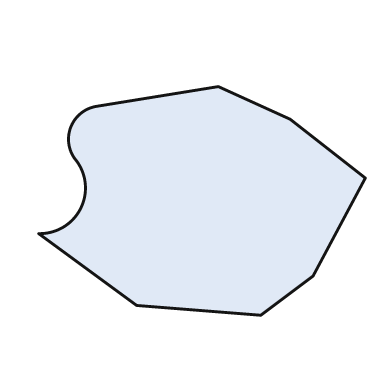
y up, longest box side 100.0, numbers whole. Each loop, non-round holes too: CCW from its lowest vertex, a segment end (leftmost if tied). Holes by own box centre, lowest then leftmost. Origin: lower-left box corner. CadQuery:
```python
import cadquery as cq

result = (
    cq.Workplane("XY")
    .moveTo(68.0, 0.0)
    .lineTo(84.0, 12.0)
    .lineTo(100.0, 42.0)
    .lineTo(77.0, 60.0)
    .lineTo(55.0, 70.0)
    .lineTo(18.0, 64.0)
    .threePointArc((10.0, 58.0), (11.0, 48.0))
    .threePointArc((13.0, 33.0), (0.0, 25.0))
    .lineTo(30.0, 3.0)
    .close()
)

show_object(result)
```